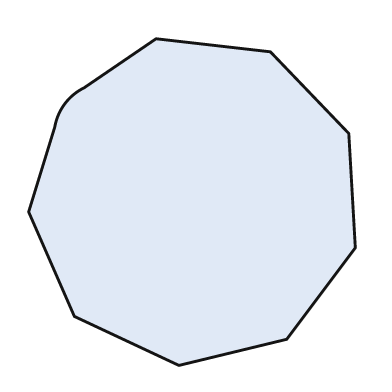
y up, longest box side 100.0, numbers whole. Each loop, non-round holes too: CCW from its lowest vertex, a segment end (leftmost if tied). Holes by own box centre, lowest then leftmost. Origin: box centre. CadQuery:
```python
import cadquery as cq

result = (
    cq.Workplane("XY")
    .moveTo(-4.0, -50.0)
    .lineTo(29.0, -42.0)
    .lineTo(50.0, -14.0)
    .lineTo(48.0, 21.0)
    .lineTo(24.0, 46.0)
    .lineTo(-11.0, 50.0)
    .lineTo(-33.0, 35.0)
    .threePointArc((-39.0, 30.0), (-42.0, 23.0))
    .lineTo(-50.0, -3.0)
    .lineTo(-36.0, -35.0)
    .close()
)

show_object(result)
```